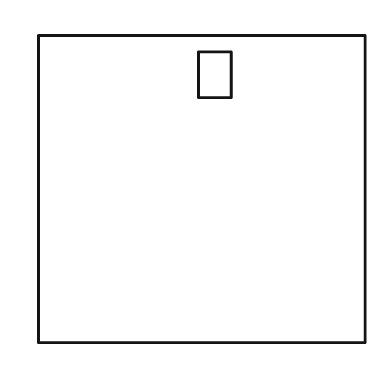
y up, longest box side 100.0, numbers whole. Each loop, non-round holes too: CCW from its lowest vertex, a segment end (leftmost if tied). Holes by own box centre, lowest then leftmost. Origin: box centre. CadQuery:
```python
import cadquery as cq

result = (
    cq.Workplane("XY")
    .moveTo(-50.0, -47.0)
    .lineTo(50.0, -47.0)
    .lineTo(50.0, 47.0)
    .lineTo(-50.0, 47.0)
    .close()
    .moveTo(-1.0, 28.0)
    .lineTo(9.0, 28.0)
    .lineTo(9.0, 42.0)
    .lineTo(-1.0, 42.0)
    .close()
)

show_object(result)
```